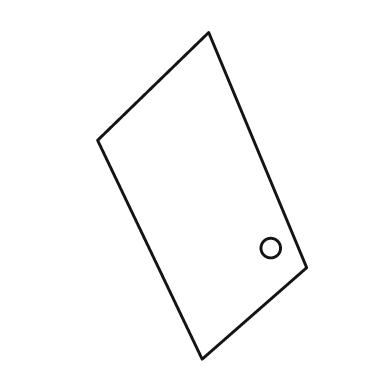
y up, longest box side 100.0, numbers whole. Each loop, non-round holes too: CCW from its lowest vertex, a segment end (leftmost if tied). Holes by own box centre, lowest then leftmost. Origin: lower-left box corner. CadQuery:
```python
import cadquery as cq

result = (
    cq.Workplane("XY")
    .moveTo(32.0, 0.0)
    .lineTo(64.0, 28.0)
    .lineTo(34.0, 100.0)
    .lineTo(0.0, 67.0)
    .close()
    .moveTo(53.0, 34.0)
    .circle(3.0)
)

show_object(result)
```